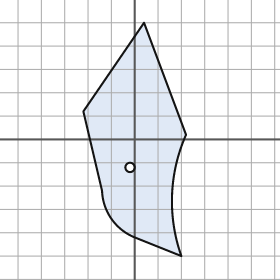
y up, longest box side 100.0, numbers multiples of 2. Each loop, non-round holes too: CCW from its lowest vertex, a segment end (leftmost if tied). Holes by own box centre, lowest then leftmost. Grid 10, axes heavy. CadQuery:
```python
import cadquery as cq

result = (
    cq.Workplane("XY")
    .moveTo(20.0, -50.0)
    .threePointArc((16.0, -24.0), (22.0, 2.0))
    .lineTo(4.0, 50.0)
    .lineTo(-22.0, 12.0)
    .lineTo(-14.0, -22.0)
    .threePointArc((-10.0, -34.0), (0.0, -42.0))
    .close()
    .moveTo(-2.0, -12.0)
    .circle(2.0)
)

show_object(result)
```